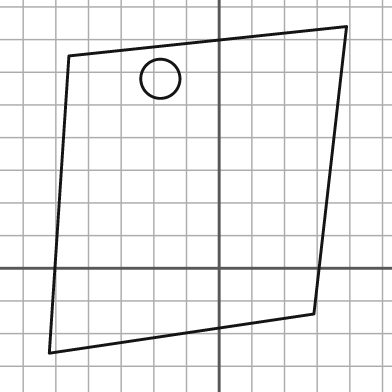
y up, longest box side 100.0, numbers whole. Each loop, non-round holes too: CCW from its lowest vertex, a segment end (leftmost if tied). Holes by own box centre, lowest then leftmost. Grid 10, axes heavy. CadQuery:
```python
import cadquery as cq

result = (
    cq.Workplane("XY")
    .moveTo(-52.0, -26.0)
    .lineTo(29.0, -14.0)
    .lineTo(39.0, 74.0)
    .lineTo(-46.0, 65.0)
    .close()
    .moveTo(-18.0, 58.0)
    .circle(6.0)
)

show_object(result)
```